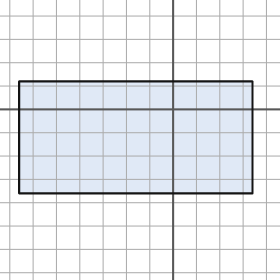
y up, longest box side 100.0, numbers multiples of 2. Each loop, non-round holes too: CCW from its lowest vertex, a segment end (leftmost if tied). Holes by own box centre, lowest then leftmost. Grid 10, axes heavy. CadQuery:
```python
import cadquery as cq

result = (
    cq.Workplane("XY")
    .moveTo(-66.0, -36.0)
    .lineTo(34.0, -36.0)
    .lineTo(34.0, 12.0)
    .lineTo(-66.0, 12.0)
    .close()
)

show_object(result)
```